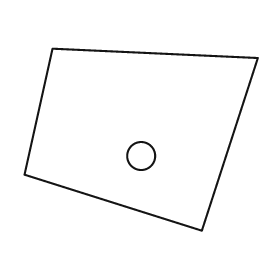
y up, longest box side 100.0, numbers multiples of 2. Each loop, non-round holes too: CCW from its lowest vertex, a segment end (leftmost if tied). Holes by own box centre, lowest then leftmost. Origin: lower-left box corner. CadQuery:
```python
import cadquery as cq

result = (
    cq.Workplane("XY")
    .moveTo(76.0, 0.0)
    .lineTo(100.0, 74.0)
    .lineTo(12.0, 78.0)
    .lineTo(0.0, 24.0)
    .close()
    .moveTo(50.0, 32.0)
    .circle(6.0)
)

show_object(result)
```